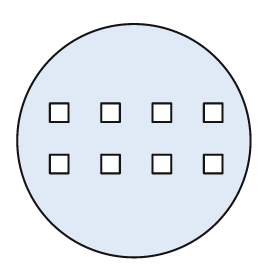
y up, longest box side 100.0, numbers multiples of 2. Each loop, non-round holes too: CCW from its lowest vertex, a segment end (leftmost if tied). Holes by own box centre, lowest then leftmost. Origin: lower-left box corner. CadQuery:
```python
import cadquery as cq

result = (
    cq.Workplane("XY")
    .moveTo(50.0, 50.0)
    .circle(50.0)
    .moveTo(14.0, 36.0)
    .lineTo(22.0, 36.0)
    .lineTo(22.0, 44.0)
    .lineTo(14.0, 44.0)
    .close()
    .moveTo(36.0, 36.0)
    .lineTo(44.0, 36.0)
    .lineTo(44.0, 44.0)
    .lineTo(36.0, 44.0)
    .close()
    .moveTo(58.0, 36.0)
    .lineTo(66.0, 36.0)
    .lineTo(66.0, 44.0)
    .lineTo(58.0, 44.0)
    .close()
    .moveTo(80.0, 36.0)
    .lineTo(88.0, 36.0)
    .lineTo(88.0, 44.0)
    .lineTo(80.0, 44.0)
    .close()
    .moveTo(14.0, 58.0)
    .lineTo(22.0, 58.0)
    .lineTo(22.0, 66.0)
    .lineTo(14.0, 66.0)
    .close()
    .moveTo(36.0, 58.0)
    .lineTo(44.0, 58.0)
    .lineTo(44.0, 66.0)
    .lineTo(36.0, 66.0)
    .close()
    .moveTo(58.0, 58.0)
    .lineTo(66.0, 58.0)
    .lineTo(66.0, 66.0)
    .lineTo(58.0, 66.0)
    .close()
    .moveTo(80.0, 58.0)
    .lineTo(88.0, 58.0)
    .lineTo(88.0, 66.0)
    .lineTo(80.0, 66.0)
    .close()
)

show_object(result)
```